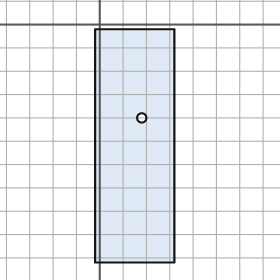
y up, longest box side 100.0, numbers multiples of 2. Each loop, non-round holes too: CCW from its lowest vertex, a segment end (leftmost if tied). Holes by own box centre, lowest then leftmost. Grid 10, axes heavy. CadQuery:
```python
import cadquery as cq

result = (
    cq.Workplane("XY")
    .moveTo(-2.0, -102.0)
    .lineTo(32.0, -102.0)
    .lineTo(32.0, -2.0)
    .lineTo(-2.0, -2.0)
    .close()
    .moveTo(18.0, -40.0)
    .circle(2.0)
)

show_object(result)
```